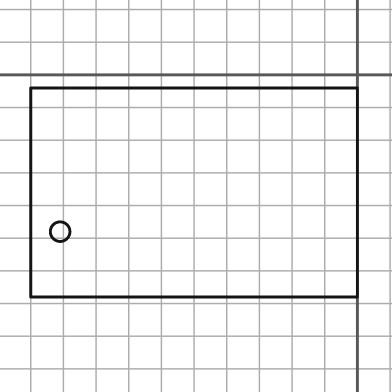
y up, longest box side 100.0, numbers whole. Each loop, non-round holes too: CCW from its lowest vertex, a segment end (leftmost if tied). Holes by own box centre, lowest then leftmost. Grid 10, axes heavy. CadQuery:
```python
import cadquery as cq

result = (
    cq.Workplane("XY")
    .moveTo(-100.0, -68.0)
    .lineTo(0.0, -68.0)
    .lineTo(0.0, -4.0)
    .lineTo(-100.0, -4.0)
    .close()
    .moveTo(-91.0, -48.0)
    .circle(3.0)
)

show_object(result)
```